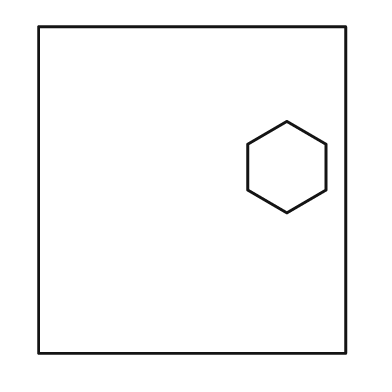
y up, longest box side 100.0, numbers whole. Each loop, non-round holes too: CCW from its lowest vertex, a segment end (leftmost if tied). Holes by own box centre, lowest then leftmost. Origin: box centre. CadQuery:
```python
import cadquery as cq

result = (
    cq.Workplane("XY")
    .moveTo(-47.0, -50.0)
    .lineTo(47.0, -50.0)
    .lineTo(47.0, 50.0)
    .lineTo(-47.0, 50.0)
    .close()
    .moveTo(29.0, -7.0)
    .lineTo(41.0, 0.0)
    .lineTo(41.0, 14.0)
    .lineTo(29.0, 21.0)
    .lineTo(17.0, 14.0)
    .lineTo(17.0, 0.0)
    .close()
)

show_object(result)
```